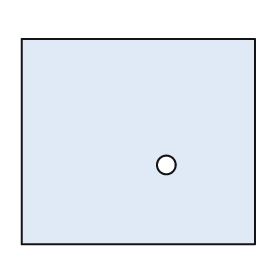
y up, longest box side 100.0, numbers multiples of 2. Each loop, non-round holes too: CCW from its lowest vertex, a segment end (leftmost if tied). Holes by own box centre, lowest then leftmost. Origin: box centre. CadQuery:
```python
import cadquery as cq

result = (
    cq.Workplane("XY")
    .moveTo(-50.0, -44.0)
    .lineTo(50.0, -44.0)
    .lineTo(50.0, 44.0)
    .lineTo(-50.0, 44.0)
    .close()
    .moveTo(12.0, -10.0)
    .circle(4.0)
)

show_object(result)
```